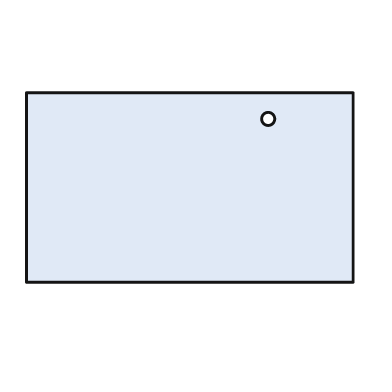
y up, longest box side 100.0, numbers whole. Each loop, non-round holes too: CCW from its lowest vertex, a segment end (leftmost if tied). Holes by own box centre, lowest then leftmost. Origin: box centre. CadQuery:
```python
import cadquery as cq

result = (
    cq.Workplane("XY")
    .moveTo(-50.0, -29.0)
    .lineTo(50.0, -29.0)
    .lineTo(50.0, 29.0)
    .lineTo(-50.0, 29.0)
    .close()
    .moveTo(24.0, 21.0)
    .circle(2.0)
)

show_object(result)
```